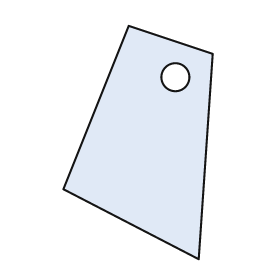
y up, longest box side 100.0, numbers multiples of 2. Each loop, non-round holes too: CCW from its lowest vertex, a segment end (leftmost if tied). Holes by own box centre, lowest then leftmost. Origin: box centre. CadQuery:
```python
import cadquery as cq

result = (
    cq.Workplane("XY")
    .moveTo(26.0, -50.0)
    .lineTo(32.0, 38.0)
    .lineTo(-4.0, 50.0)
    .lineTo(-32.0, -20.0)
    .close()
    .moveTo(16.0, 28.0)
    .circle(6.0)
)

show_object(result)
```